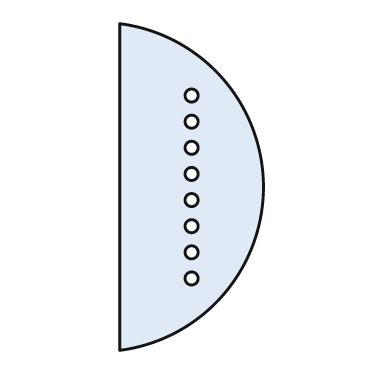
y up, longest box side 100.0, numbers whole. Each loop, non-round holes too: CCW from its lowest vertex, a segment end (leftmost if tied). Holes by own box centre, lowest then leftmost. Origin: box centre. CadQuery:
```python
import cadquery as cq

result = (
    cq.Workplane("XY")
    .moveTo(-22.0, -50.0)
    .threePointArc((22.0, 0.0), (-22.0, 50.0))
    .close()
    .moveTo(0.0, -28.0)
    .circle(2.0)
    .moveTo(0.0, -20.0)
    .circle(2.0)
    .moveTo(0.0, -12.0)
    .circle(2.0)
    .moveTo(0.0, -4.0)
    .circle(2.0)
    .moveTo(0.0, 4.0)
    .circle(2.0)
    .moveTo(0.0, 12.0)
    .circle(2.0)
    .moveTo(0.0, 20.0)
    .circle(2.0)
    .moveTo(0.0, 28.0)
    .circle(2.0)
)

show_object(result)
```